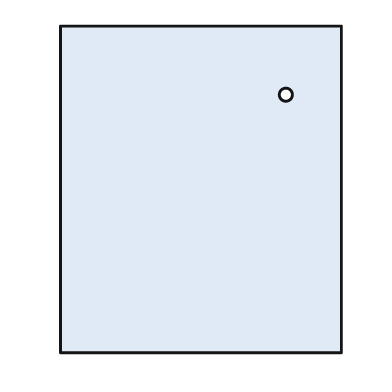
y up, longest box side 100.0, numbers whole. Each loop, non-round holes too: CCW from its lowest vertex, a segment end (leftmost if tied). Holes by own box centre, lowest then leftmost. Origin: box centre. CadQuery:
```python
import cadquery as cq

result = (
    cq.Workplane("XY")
    .moveTo(-43.0, -50.0)
    .lineTo(43.0, -50.0)
    .lineTo(43.0, 50.0)
    .lineTo(-43.0, 50.0)
    .close()
    .moveTo(26.0, 29.0)
    .circle(2.0)
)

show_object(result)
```